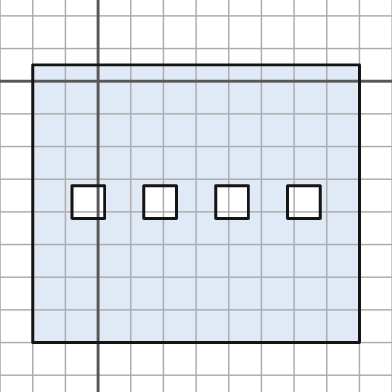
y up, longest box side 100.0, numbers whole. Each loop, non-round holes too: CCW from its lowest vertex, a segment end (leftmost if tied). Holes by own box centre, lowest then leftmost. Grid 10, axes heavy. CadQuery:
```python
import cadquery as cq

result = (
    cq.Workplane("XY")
    .moveTo(-20.0, -80.0)
    .lineTo(80.0, -80.0)
    .lineTo(80.0, 5.0)
    .lineTo(-20.0, 5.0)
    .close()
    .moveTo(-8.0, -42.0)
    .lineTo(2.0, -42.0)
    .lineTo(2.0, -32.0)
    .lineTo(-8.0, -32.0)
    .close()
    .moveTo(14.0, -42.0)
    .lineTo(24.0, -42.0)
    .lineTo(24.0, -32.0)
    .lineTo(14.0, -32.0)
    .close()
    .moveTo(36.0, -42.0)
    .lineTo(46.0, -42.0)
    .lineTo(46.0, -32.0)
    .lineTo(36.0, -32.0)
    .close()
    .moveTo(58.0, -42.0)
    .lineTo(68.0, -42.0)
    .lineTo(68.0, -32.0)
    .lineTo(58.0, -32.0)
    .close()
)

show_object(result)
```